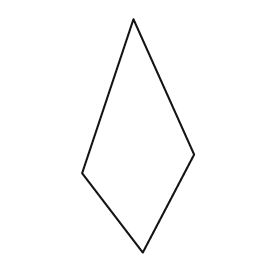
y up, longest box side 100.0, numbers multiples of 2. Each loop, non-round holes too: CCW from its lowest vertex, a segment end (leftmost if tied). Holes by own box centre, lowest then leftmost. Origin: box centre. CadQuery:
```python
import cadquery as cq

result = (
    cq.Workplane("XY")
    .moveTo(2.0, -50.0)
    .lineTo(24.0, -8.0)
    .lineTo(-2.0, 50.0)
    .lineTo(-24.0, -16.0)
    .close()
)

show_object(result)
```